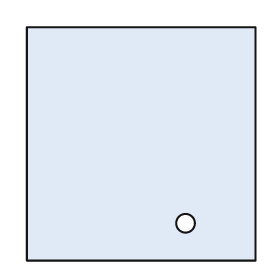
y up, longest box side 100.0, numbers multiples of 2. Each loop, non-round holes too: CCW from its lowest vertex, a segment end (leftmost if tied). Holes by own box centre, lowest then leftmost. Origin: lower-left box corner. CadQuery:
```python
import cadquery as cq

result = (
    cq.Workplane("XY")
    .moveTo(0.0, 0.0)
    .lineTo(98.0, 0.0)
    .lineTo(98.0, 100.0)
    .lineTo(0.0, 100.0)
    .close()
    .moveTo(68.0, 16.0)
    .circle(4.0)
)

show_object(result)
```